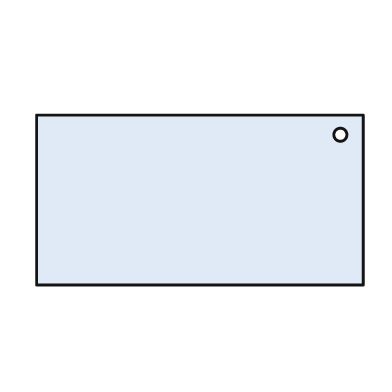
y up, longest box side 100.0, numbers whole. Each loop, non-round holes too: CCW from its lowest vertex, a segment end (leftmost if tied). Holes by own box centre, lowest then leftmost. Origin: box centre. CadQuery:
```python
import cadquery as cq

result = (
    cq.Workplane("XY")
    .moveTo(-50.0, -26.0)
    .lineTo(50.0, -26.0)
    .lineTo(50.0, 26.0)
    .lineTo(-50.0, 26.0)
    .close()
    .moveTo(43.0, 20.0)
    .circle(2.0)
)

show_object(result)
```